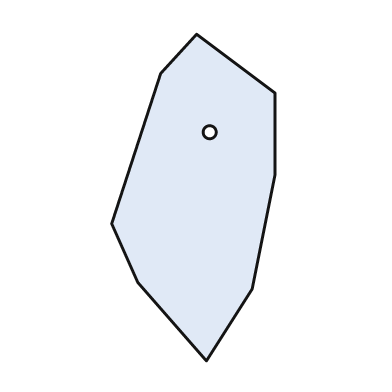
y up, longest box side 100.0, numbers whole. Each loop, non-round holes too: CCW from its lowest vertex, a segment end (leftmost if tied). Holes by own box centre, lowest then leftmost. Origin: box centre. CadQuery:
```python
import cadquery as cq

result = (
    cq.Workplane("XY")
    .moveTo(4.0, -50.0)
    .lineTo(18.0, -28.0)
    .lineTo(25.0, 7.0)
    .lineTo(25.0, 32.0)
    .lineTo(1.0, 50.0)
    .lineTo(-10.0, 38.0)
    .lineTo(-25.0, -8.0)
    .lineTo(-17.0, -26.0)
    .close()
    .moveTo(5.0, 20.0)
    .circle(2.0)
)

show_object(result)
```